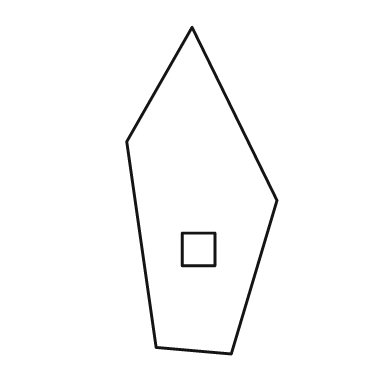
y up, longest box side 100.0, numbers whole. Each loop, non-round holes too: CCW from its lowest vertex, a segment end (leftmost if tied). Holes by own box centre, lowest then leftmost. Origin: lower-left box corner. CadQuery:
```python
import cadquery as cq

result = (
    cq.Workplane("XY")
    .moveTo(32.0, 0.0)
    .lineTo(46.0, 47.0)
    .lineTo(20.0, 100.0)
    .lineTo(0.0, 65.0)
    .lineTo(9.0, 2.0)
    .close()
    .moveTo(17.0, 27.0)
    .lineTo(27.0, 27.0)
    .lineTo(27.0, 37.0)
    .lineTo(17.0, 37.0)
    .close()
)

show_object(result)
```